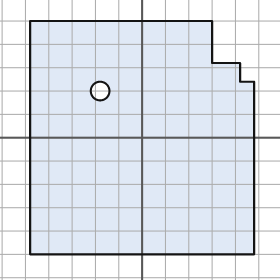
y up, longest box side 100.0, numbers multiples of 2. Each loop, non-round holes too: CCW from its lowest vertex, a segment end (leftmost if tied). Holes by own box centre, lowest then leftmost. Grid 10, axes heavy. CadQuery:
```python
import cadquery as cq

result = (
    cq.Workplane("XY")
    .moveTo(-48.0, -50.0)
    .lineTo(48.0, -50.0)
    .lineTo(48.0, 24.0)
    .lineTo(42.0, 24.0)
    .lineTo(42.0, 32.0)
    .lineTo(30.0, 32.0)
    .lineTo(30.0, 50.0)
    .lineTo(-48.0, 50.0)
    .close()
    .moveTo(-18.0, 20.0)
    .circle(4.0)
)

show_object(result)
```